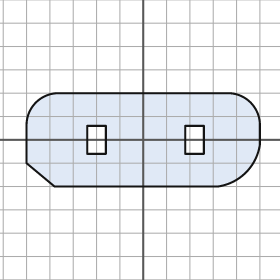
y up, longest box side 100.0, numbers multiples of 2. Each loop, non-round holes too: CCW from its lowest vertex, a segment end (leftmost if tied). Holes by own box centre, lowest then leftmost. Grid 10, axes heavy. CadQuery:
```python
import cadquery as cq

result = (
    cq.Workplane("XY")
    .moveTo(-38.0, -20.0)
    .lineTo(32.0, -20.0)
    .threePointArc((44.0, -14.0), (50.0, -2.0))
    .lineTo(50.0, 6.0)
    .threePointArc((46.0, 16.0), (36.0, 20.0))
    .lineTo(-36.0, 20.0)
    .threePointArc((-46.0, 16.0), (-50.0, 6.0))
    .lineTo(-50.0, -10.0)
    .close()
    .moveTo(-24.0, -6.0)
    .lineTo(-16.0, -6.0)
    .lineTo(-16.0, 6.0)
    .lineTo(-24.0, 6.0)
    .close()
    .moveTo(18.0, -6.0)
    .lineTo(26.0, -6.0)
    .lineTo(26.0, 6.0)
    .lineTo(18.0, 6.0)
    .close()
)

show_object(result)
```